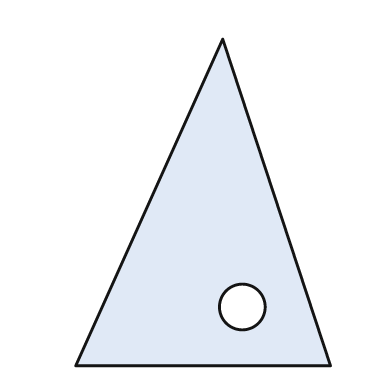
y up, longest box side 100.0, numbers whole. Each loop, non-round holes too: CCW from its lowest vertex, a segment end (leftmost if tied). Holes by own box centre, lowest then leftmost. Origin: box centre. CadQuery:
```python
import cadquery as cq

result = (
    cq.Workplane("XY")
    .moveTo(-39.0, -50.0)
    .lineTo(39.0, -50.0)
    .lineTo(6.0, 50.0)
    .close()
    .moveTo(12.0, -32.0)
    .circle(7.0)
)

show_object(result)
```